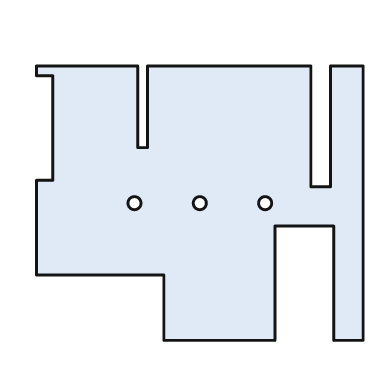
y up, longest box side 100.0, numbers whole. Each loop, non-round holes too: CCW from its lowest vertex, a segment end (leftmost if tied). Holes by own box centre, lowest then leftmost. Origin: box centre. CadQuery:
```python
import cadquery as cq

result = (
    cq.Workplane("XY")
    .moveTo(-11.0, -42.0)
    .lineTo(23.0, -42.0)
    .lineTo(23.0, -7.0)
    .lineTo(41.0, -7.0)
    .lineTo(41.0, -42.0)
    .lineTo(50.0, -42.0)
    .lineTo(50.0, 42.0)
    .lineTo(40.0, 42.0)
    .lineTo(40.0, 5.0)
    .lineTo(34.0, 5.0)
    .lineTo(34.0, 42.0)
    .lineTo(-16.0, 42.0)
    .lineTo(-16.0, 17.0)
    .lineTo(-19.0, 17.0)
    .lineTo(-19.0, 42.0)
    .lineTo(-50.0, 42.0)
    .lineTo(-50.0, 39.0)
    .lineTo(-45.0, 39.0)
    .lineTo(-45.0, 7.0)
    .lineTo(-50.0, 7.0)
    .lineTo(-50.0, -22.0)
    .lineTo(-11.0, -22.0)
    .close()
    .moveTo(-20.0, 0.0)
    .circle(2.0)
    .moveTo(0.0, 0.0)
    .circle(2.0)
    .moveTo(20.0, 0.0)
    .circle(2.0)
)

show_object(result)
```